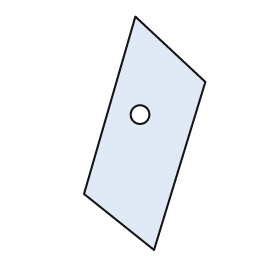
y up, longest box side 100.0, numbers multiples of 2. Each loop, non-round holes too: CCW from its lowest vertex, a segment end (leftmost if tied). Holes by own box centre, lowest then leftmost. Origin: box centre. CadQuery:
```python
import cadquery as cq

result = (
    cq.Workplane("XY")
    .moveTo(4.0, -50.0)
    .lineTo(26.0, 22.0)
    .lineTo(-4.0, 50.0)
    .lineTo(-26.0, -26.0)
    .close()
    .moveTo(-2.0, 8.0)
    .circle(4.0)
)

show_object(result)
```